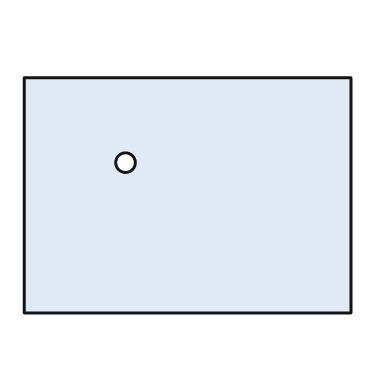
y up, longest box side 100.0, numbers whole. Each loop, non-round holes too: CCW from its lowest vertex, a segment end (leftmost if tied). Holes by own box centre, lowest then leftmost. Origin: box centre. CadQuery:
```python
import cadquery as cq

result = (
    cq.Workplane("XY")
    .moveTo(-50.0, -36.0)
    .lineTo(50.0, -36.0)
    .lineTo(50.0, 36.0)
    .lineTo(-50.0, 36.0)
    .close()
    .moveTo(-19.0, 10.0)
    .circle(3.0)
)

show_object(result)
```